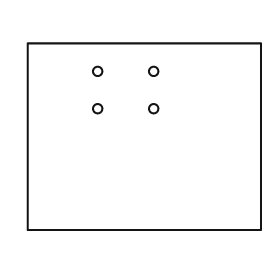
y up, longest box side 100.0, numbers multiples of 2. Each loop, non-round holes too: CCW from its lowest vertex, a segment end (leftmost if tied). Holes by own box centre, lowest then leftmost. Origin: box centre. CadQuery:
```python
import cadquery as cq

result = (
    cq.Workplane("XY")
    .moveTo(-50.0, -40.0)
    .lineTo(50.0, -40.0)
    .lineTo(50.0, 40.0)
    .lineTo(-50.0, 40.0)
    .close()
    .moveTo(-20.0, 12.0)
    .circle(2.0)
    .moveTo(4.0, 12.0)
    .circle(2.0)
    .moveTo(-20.0, 28.0)
    .circle(2.0)
    .moveTo(4.0, 28.0)
    .circle(2.0)
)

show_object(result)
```